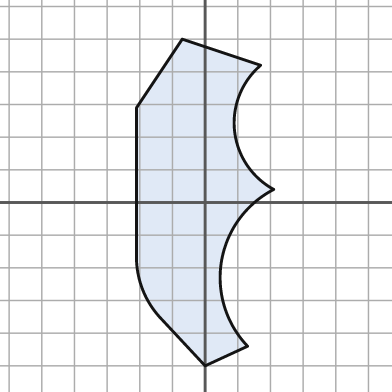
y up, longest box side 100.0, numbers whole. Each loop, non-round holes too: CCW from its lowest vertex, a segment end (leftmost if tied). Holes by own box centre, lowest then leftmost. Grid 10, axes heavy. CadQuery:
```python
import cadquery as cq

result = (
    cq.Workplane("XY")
    .moveTo(0.0, -50.0)
    .lineTo(13.0, -44.0)
    .threePointArc((5.0, -18.0), (21.0, 4.0))
    .threePointArc((9.0, 22.0), (17.0, 42.0))
    .lineTo(-7.0, 50.0)
    .lineTo(-21.0, 29.0)
    .lineTo(-21.0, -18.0)
    .threePointArc((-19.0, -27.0), (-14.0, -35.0))
    .close()
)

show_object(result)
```